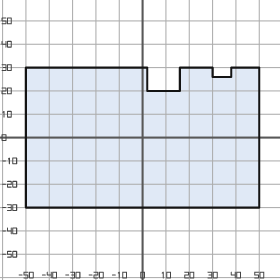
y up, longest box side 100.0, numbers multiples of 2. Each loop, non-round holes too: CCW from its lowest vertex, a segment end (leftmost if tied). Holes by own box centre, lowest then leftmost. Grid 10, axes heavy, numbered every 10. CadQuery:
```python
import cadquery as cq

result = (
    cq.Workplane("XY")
    .moveTo(-50.0, -30.0)
    .lineTo(50.0, -30.0)
    .lineTo(50.0, 30.0)
    .lineTo(38.0, 30.0)
    .lineTo(38.0, 26.0)
    .lineTo(30.0, 26.0)
    .lineTo(30.0, 30.0)
    .lineTo(16.0, 30.0)
    .lineTo(16.0, 20.0)
    .lineTo(2.0, 20.0)
    .lineTo(2.0, 30.0)
    .lineTo(-50.0, 30.0)
    .close()
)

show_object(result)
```